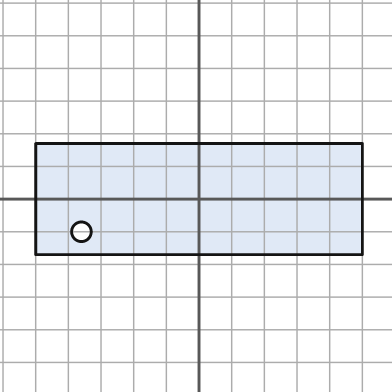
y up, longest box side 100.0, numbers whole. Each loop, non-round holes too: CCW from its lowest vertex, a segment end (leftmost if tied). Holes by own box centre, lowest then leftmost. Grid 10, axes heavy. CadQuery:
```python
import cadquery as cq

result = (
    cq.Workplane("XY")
    .moveTo(-50.0, -17.0)
    .lineTo(50.0, -17.0)
    .lineTo(50.0, 17.0)
    .lineTo(-50.0, 17.0)
    .close()
    .moveTo(-36.0, -10.0)
    .circle(3.0)
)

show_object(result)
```